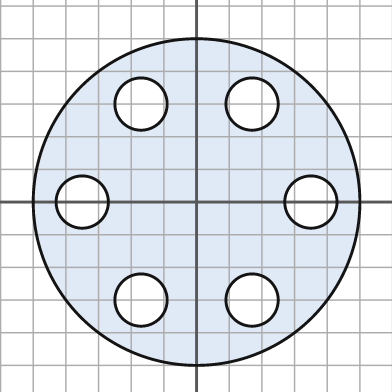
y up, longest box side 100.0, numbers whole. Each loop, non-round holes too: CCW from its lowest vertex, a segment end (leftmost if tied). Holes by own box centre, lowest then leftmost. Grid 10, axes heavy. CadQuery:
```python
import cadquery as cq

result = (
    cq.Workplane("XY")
    .moveTo(0.0, 0.0)
    .circle(50.0)
    .moveTo(-17.0, -30.0)
    .circle(8.0)
    .moveTo(17.0, -30.0)
    .circle(8.0)
    .moveTo(-35.0, 0.0)
    .circle(8.0)
    .moveTo(35.0, 0.0)
    .circle(8.0)
    .moveTo(-17.0, 30.0)
    .circle(8.0)
    .moveTo(17.0, 30.0)
    .circle(8.0)
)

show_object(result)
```